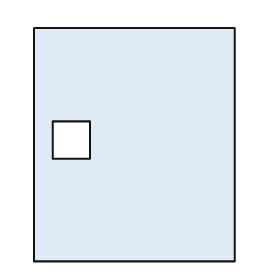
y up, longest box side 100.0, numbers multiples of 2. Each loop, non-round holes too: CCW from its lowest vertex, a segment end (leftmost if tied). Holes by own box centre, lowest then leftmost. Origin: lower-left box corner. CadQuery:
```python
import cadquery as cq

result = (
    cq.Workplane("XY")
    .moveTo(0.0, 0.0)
    .lineTo(86.0, 0.0)
    .lineTo(86.0, 100.0)
    .lineTo(0.0, 100.0)
    .close()
    .moveTo(8.0, 44.0)
    .lineTo(24.0, 44.0)
    .lineTo(24.0, 60.0)
    .lineTo(8.0, 60.0)
    .close()
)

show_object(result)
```